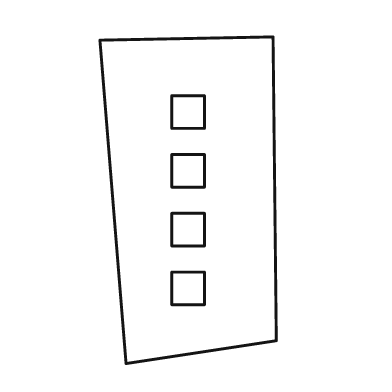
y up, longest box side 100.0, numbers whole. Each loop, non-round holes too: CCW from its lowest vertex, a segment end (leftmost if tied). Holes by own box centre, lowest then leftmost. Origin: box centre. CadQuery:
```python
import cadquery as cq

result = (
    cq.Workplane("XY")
    .moveTo(-19.0, -50.0)
    .lineTo(27.0, -43.0)
    .lineTo(26.0, 50.0)
    .lineTo(-27.0, 49.0)
    .close()
    .moveTo(-5.0, -32.0)
    .lineTo(5.0, -32.0)
    .lineTo(5.0, -22.0)
    .lineTo(-5.0, -22.0)
    .close()
    .moveTo(-5.0, -14.0)
    .lineTo(5.0, -14.0)
    .lineTo(5.0, -4.0)
    .lineTo(-5.0, -4.0)
    .close()
    .moveTo(-5.0, 4.0)
    .lineTo(5.0, 4.0)
    .lineTo(5.0, 14.0)
    .lineTo(-5.0, 14.0)
    .close()
    .moveTo(-5.0, 22.0)
    .lineTo(5.0, 22.0)
    .lineTo(5.0, 32.0)
    .lineTo(-5.0, 32.0)
    .close()
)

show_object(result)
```